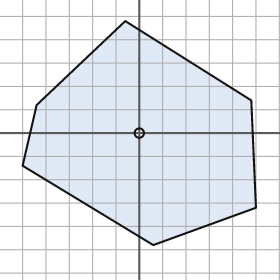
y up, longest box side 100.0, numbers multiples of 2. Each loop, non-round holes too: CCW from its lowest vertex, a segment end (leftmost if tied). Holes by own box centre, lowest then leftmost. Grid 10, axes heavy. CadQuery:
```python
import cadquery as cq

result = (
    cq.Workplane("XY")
    .moveTo(6.0, -48.0)
    .lineTo(50.0, -32.0)
    .lineTo(48.0, 14.0)
    .lineTo(-6.0, 48.0)
    .lineTo(-44.0, 12.0)
    .lineTo(-50.0, -14.0)
    .close()
    .moveTo(0.0, 0.0)
    .circle(2.0)
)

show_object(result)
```